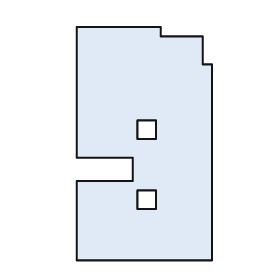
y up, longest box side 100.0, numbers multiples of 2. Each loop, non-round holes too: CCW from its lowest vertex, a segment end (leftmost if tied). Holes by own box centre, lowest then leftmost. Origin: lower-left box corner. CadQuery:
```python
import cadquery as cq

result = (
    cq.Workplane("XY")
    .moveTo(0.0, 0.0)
    .lineTo(58.0, 0.0)
    .lineTo(58.0, 84.0)
    .lineTo(54.0, 84.0)
    .lineTo(54.0, 96.0)
    .lineTo(36.0, 96.0)
    .lineTo(36.0, 100.0)
    .lineTo(0.0, 100.0)
    .lineTo(0.0, 44.0)
    .lineTo(24.0, 44.0)
    .lineTo(24.0, 34.0)
    .lineTo(0.0, 34.0)
    .close()
    .moveTo(26.0, 22.0)
    .lineTo(34.0, 22.0)
    .lineTo(34.0, 30.0)
    .lineTo(26.0, 30.0)
    .close()
    .moveTo(26.0, 52.0)
    .lineTo(34.0, 52.0)
    .lineTo(34.0, 60.0)
    .lineTo(26.0, 60.0)
    .close()
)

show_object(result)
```